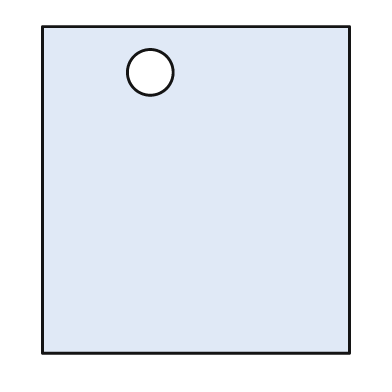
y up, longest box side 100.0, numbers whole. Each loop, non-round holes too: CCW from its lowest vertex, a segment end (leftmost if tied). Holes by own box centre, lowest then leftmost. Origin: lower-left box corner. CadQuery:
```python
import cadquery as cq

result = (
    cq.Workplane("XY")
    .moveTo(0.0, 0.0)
    .lineTo(94.0, 0.0)
    .lineTo(94.0, 100.0)
    .lineTo(0.0, 100.0)
    .close()
    .moveTo(33.0, 86.0)
    .circle(7.0)
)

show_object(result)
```